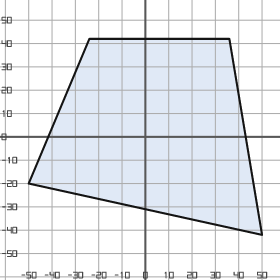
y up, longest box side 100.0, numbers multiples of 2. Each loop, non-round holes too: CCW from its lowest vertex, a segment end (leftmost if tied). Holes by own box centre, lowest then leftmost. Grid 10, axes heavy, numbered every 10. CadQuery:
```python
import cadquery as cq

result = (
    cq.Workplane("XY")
    .moveTo(50.0, -42.0)
    .lineTo(36.0, 42.0)
    .lineTo(-24.0, 42.0)
    .lineTo(-50.0, -20.0)
    .close()
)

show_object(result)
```